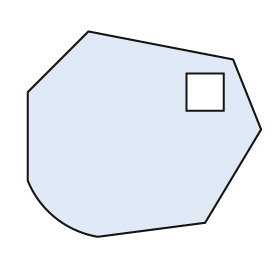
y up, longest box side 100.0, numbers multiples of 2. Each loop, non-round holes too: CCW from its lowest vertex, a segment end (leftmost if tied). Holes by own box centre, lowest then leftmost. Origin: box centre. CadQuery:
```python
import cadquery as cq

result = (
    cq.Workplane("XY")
    .moveTo(-20.0, -44.0)
    .lineTo(26.0, -38.0)
    .lineTo(50.0, 2.0)
    .lineTo(38.0, 32.0)
    .lineTo(-24.0, 44.0)
    .lineTo(-50.0, 18.0)
    .lineTo(-50.0, -20.0)
    .threePointArc((-38.0, -36.0), (-20.0, -44.0))
    .close()
    .moveTo(18.0, 10.0)
    .lineTo(34.0, 10.0)
    .lineTo(34.0, 26.0)
    .lineTo(18.0, 26.0)
    .close()
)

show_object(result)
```